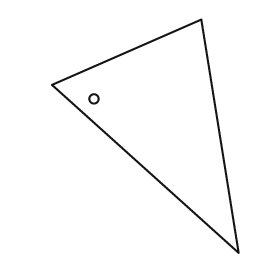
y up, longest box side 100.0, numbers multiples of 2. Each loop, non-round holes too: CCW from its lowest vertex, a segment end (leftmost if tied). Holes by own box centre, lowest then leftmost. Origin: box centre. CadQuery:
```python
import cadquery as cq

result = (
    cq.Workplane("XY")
    .moveTo(40.0, -50.0)
    .lineTo(24.0, 50.0)
    .lineTo(-40.0, 22.0)
    .close()
    .moveTo(-22.0, 16.0)
    .circle(2.0)
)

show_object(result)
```